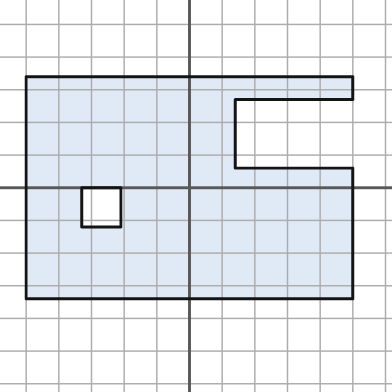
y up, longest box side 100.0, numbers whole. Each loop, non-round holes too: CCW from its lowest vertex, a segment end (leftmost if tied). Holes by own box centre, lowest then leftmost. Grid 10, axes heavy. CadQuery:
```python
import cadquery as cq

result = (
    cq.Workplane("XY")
    .moveTo(-50.0, -34.0)
    .lineTo(50.0, -34.0)
    .lineTo(50.0, 6.0)
    .lineTo(14.0, 6.0)
    .lineTo(14.0, 27.0)
    .lineTo(50.0, 27.0)
    .lineTo(50.0, 34.0)
    .lineTo(-50.0, 34.0)
    .close()
    .moveTo(-33.0, -12.0)
    .lineTo(-21.0, -12.0)
    .lineTo(-21.0, 0.0)
    .lineTo(-33.0, 0.0)
    .close()
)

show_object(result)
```